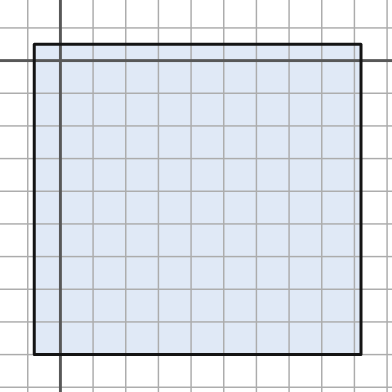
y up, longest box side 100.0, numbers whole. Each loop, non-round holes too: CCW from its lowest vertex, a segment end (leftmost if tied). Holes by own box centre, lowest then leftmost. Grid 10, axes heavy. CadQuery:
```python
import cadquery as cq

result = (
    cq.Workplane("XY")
    .moveTo(-8.0, -90.0)
    .lineTo(92.0, -90.0)
    .lineTo(92.0, 5.0)
    .lineTo(-8.0, 5.0)
    .close()
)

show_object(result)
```